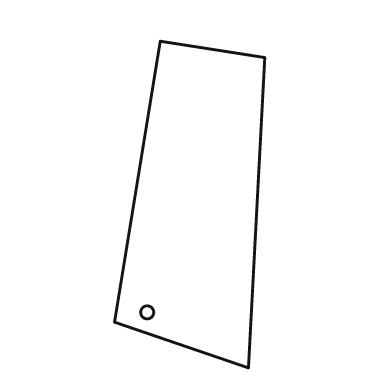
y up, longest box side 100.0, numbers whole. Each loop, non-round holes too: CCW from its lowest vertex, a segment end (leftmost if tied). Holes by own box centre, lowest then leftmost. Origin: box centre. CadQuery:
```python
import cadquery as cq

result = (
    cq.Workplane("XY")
    .moveTo(18.0, -50.0)
    .lineTo(23.0, 45.0)
    .lineTo(-9.0, 50.0)
    .lineTo(-23.0, -36.0)
    .close()
    .moveTo(-13.0, -33.0)
    .circle(2.0)
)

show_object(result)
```